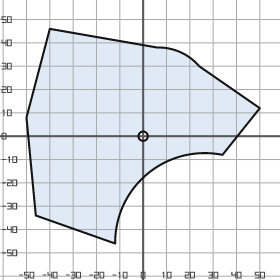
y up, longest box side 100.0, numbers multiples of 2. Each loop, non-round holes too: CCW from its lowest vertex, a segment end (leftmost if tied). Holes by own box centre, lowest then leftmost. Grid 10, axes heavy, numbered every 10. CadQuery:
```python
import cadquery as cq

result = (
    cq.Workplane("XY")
    .moveTo(-12.0, -46.0)
    .threePointArc((2.0, -16.0), (34.0, -8.0))
    .lineTo(50.0, 12.0)
    .lineTo(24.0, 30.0)
    .threePointArc((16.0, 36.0), (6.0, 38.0))
    .lineTo(-40.0, 46.0)
    .lineTo(-50.0, 8.0)
    .lineTo(-46.0, -34.0)
    .close()
    .moveTo(0.0, 0.0)
    .circle(2.0)
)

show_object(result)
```